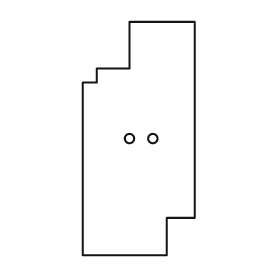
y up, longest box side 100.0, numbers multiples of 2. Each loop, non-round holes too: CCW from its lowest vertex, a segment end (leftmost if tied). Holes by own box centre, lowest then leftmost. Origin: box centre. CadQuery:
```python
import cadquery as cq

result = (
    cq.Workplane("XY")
    .moveTo(-24.0, -50.0)
    .lineTo(12.0, -50.0)
    .lineTo(12.0, -34.0)
    .lineTo(24.0, -34.0)
    .lineTo(24.0, 50.0)
    .lineTo(-4.0, 50.0)
    .lineTo(-4.0, 30.0)
    .lineTo(-18.0, 30.0)
    .lineTo(-18.0, 24.0)
    .lineTo(-24.0, 24.0)
    .close()
    .moveTo(-4.0, 0.0)
    .circle(2.0)
    .moveTo(6.0, 0.0)
    .circle(2.0)
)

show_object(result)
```